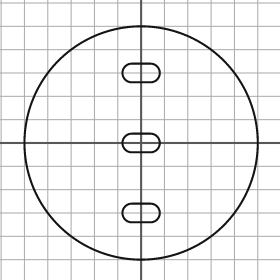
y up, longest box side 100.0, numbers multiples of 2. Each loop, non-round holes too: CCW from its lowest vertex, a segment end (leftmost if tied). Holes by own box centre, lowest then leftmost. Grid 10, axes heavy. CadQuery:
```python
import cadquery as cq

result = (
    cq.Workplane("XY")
    .moveTo(0.0, 0.0)
    .circle(50.0)
    .moveTo(-4.0, -34.0)
    .lineTo(4.0, -34.0)
    .threePointArc((8.0, -30.0), (4.0, -26.0))
    .lineTo(-4.0, -26.0)
    .threePointArc((-8.0, -30.0), (-4.0, -34.0))
    .close()
    .moveTo(-4.0, -4.0)
    .lineTo(4.0, -4.0)
    .threePointArc((8.0, 0.0), (4.0, 4.0))
    .lineTo(-4.0, 4.0)
    .threePointArc((-8.0, 0.0), (-4.0, -4.0))
    .close()
    .moveTo(-4.0, 26.0)
    .lineTo(4.0, 26.0)
    .threePointArc((8.0, 30.0), (4.0, 34.0))
    .lineTo(-4.0, 34.0)
    .threePointArc((-8.0, 30.0), (-4.0, 26.0))
    .close()
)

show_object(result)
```